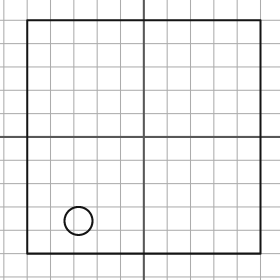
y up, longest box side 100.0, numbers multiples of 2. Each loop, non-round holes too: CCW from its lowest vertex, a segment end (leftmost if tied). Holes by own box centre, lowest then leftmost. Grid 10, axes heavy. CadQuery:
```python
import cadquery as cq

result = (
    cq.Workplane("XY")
    .moveTo(-50.0, -50.0)
    .lineTo(50.0, -50.0)
    .lineTo(50.0, 50.0)
    .lineTo(-50.0, 50.0)
    .close()
    .moveTo(-28.0, -36.0)
    .circle(6.0)
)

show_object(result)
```